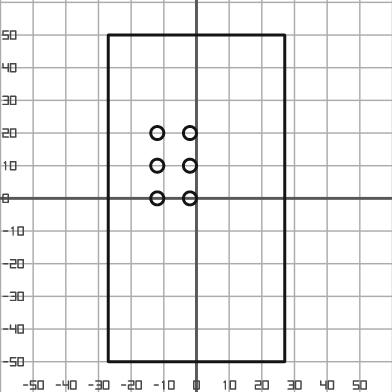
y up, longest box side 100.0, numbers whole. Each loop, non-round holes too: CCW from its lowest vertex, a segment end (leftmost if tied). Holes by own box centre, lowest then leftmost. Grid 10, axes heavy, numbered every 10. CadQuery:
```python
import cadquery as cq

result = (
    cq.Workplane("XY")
    .moveTo(-27.0, -50.0)
    .lineTo(27.0, -50.0)
    .lineTo(27.0, 50.0)
    .lineTo(-27.0, 50.0)
    .close()
    .moveTo(-12.0, 0.0)
    .circle(2.0)
    .moveTo(-2.0, 0.0)
    .circle(2.0)
    .moveTo(-12.0, 10.0)
    .circle(2.0)
    .moveTo(-2.0, 10.0)
    .circle(2.0)
    .moveTo(-12.0, 20.0)
    .circle(2.0)
    .moveTo(-2.0, 20.0)
    .circle(2.0)
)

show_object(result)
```